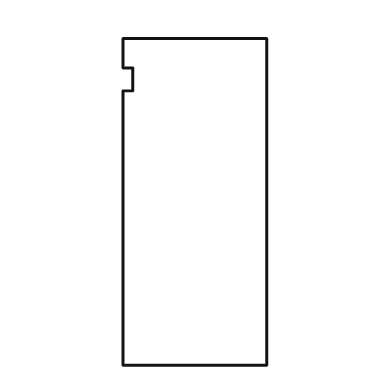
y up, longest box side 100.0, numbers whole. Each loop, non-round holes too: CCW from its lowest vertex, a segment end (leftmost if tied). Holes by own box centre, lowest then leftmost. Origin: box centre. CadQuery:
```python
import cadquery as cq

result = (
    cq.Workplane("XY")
    .moveTo(-22.0, -50.0)
    .lineTo(22.0, -50.0)
    .lineTo(22.0, 50.0)
    .lineTo(-22.0, 50.0)
    .lineTo(-22.0, 41.0)
    .lineTo(-19.0, 41.0)
    .lineTo(-19.0, 34.0)
    .lineTo(-22.0, 34.0)
    .close()
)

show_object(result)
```